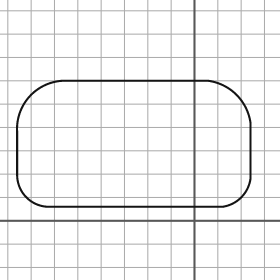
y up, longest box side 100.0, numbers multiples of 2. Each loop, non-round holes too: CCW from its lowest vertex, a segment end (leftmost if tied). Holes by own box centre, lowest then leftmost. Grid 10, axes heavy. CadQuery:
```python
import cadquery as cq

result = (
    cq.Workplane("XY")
    .moveTo(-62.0, 6.0)
    .lineTo(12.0, 6.0)
    .threePointArc((20.0, 10.0), (24.0, 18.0))
    .lineTo(24.0, 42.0)
    .threePointArc((18.0, 54.0), (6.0, 60.0))
    .lineTo(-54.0, 60.0)
    .threePointArc((-70.0, 54.0), (-76.0, 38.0))
    .lineTo(-76.0, 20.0)
    .threePointArc((-72.0, 10.0), (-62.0, 6.0))
    .close()
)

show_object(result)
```